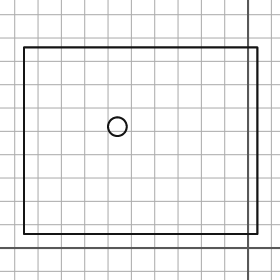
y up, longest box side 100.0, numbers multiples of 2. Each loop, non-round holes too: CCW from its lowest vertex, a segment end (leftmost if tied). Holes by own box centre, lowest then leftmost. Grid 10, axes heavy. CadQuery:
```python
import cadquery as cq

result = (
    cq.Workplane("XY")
    .moveTo(-96.0, 6.0)
    .lineTo(4.0, 6.0)
    .lineTo(4.0, 86.0)
    .lineTo(-96.0, 86.0)
    .close()
    .moveTo(-56.0, 52.0)
    .circle(4.0)
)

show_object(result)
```